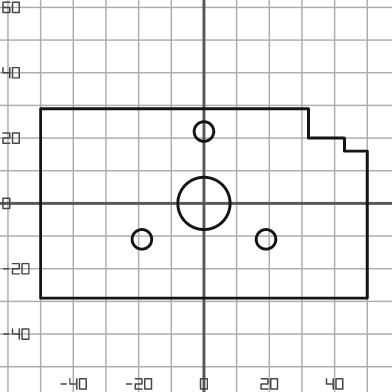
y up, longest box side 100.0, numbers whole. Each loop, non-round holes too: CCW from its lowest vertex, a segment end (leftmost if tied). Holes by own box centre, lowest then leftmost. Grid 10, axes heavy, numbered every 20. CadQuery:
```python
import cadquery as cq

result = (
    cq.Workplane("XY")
    .moveTo(-50.0, -29.0)
    .lineTo(50.0, -29.0)
    .lineTo(50.0, 16.0)
    .lineTo(43.0, 16.0)
    .lineTo(43.0, 20.0)
    .lineTo(32.0, 20.0)
    .lineTo(32.0, 29.0)
    .lineTo(-50.0, 29.0)
    .close()
    .moveTo(-19.0, -11.0)
    .circle(3.0)
    .moveTo(19.0, -11.0)
    .circle(3.0)
    .moveTo(0.0, 0.0)
    .circle(8.0)
    .moveTo(0.0, 22.0)
    .circle(3.0)
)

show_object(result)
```